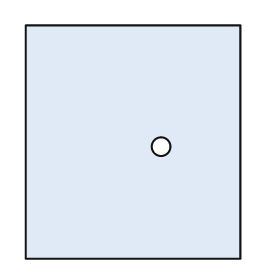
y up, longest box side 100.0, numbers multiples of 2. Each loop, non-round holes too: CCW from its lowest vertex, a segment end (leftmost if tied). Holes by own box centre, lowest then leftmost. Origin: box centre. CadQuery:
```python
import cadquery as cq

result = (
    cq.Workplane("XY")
    .moveTo(-46.0, -50.0)
    .lineTo(46.0, -50.0)
    .lineTo(46.0, 50.0)
    .lineTo(-46.0, 50.0)
    .close()
    .moveTo(12.0, -2.0)
    .circle(4.0)
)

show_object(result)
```